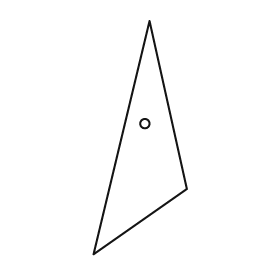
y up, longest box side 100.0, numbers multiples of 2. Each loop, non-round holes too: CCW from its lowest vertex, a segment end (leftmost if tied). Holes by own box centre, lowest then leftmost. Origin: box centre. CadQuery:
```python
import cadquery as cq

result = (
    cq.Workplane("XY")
    .moveTo(-20.0, -50.0)
    .lineTo(20.0, -22.0)
    .lineTo(4.0, 50.0)
    .close()
    .moveTo(2.0, 6.0)
    .circle(2.0)
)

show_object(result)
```